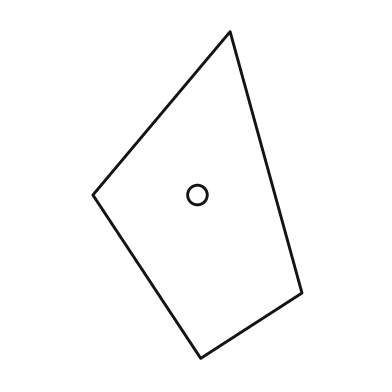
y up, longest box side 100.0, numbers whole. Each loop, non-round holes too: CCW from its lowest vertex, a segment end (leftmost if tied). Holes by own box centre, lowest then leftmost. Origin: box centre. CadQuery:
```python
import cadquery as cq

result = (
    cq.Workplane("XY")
    .moveTo(1.0, -50.0)
    .lineTo(32.0, -30.0)
    .lineTo(10.0, 50.0)
    .lineTo(-32.0, 0.0)
    .close()
    .moveTo(0.0, 0.0)
    .circle(3.0)
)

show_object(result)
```